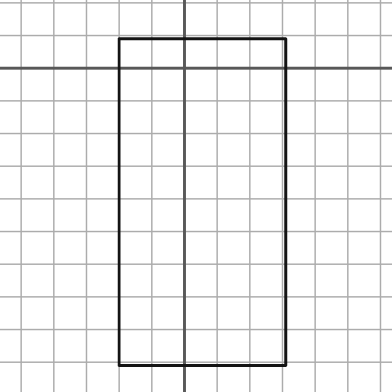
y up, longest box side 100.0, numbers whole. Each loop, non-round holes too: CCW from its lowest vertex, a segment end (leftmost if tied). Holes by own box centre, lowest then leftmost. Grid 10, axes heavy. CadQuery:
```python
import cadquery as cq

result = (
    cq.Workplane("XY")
    .moveTo(-20.0, -91.0)
    .lineTo(31.0, -91.0)
    .lineTo(31.0, 9.0)
    .lineTo(-20.0, 9.0)
    .close()
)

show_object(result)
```